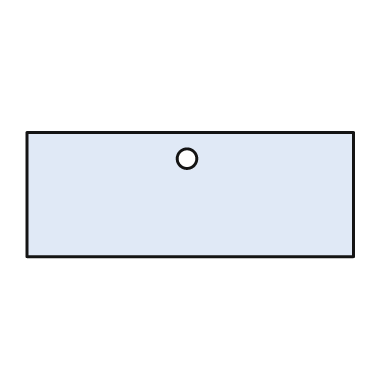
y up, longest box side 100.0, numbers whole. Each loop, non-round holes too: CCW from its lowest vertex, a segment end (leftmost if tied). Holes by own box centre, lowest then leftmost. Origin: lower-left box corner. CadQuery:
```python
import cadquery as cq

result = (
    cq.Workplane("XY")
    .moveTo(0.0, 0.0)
    .lineTo(100.0, 0.0)
    .lineTo(100.0, 38.0)
    .lineTo(0.0, 38.0)
    .close()
    .moveTo(49.0, 30.0)
    .circle(3.0)
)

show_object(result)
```